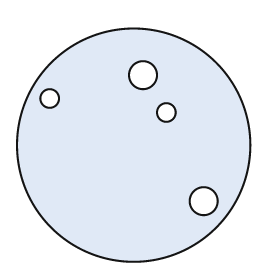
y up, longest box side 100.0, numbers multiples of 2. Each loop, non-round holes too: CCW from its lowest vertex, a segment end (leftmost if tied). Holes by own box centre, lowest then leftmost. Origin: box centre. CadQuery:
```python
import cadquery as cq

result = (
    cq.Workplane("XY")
    .moveTo(0.0, 0.0)
    .circle(50.0)
    .moveTo(30.0, -24.0)
    .circle(6.0)
    .moveTo(14.0, 14.0)
    .circle(4.0)
    .moveTo(-36.0, 20.0)
    .circle(4.0)
    .moveTo(4.0, 30.0)
    .circle(6.0)
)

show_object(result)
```